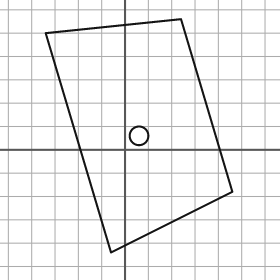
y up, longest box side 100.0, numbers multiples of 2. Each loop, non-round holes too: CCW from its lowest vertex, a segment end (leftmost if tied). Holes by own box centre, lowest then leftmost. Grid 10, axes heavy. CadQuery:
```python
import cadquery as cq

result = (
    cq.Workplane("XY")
    .moveTo(-6.0, -44.0)
    .lineTo(46.0, -18.0)
    .lineTo(24.0, 56.0)
    .lineTo(-34.0, 50.0)
    .close()
    .moveTo(6.0, 6.0)
    .circle(4.0)
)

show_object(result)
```